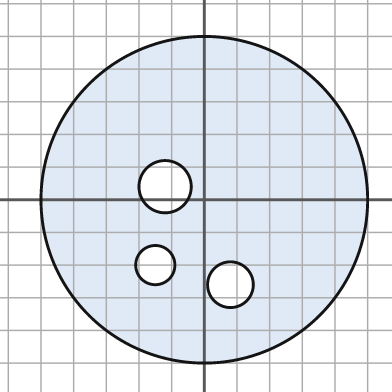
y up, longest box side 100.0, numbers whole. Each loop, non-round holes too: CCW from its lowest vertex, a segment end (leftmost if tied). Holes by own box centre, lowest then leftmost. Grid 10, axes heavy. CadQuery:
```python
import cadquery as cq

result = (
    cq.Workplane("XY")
    .moveTo(0.0, 0.0)
    .circle(50.0)
    .moveTo(8.0, -26.0)
    .circle(7.0)
    .moveTo(-15.0, -20.0)
    .circle(6.0)
    .moveTo(-12.0, 4.0)
    .circle(8.0)
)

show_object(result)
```